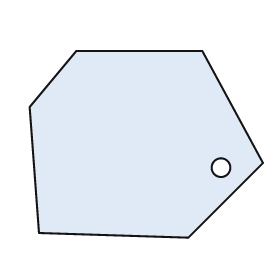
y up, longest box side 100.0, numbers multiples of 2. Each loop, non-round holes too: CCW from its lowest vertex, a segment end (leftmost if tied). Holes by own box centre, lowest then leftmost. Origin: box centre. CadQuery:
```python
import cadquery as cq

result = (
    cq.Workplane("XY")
    .moveTo(18.0, -40.0)
    .lineTo(50.0, -8.0)
    .lineTo(24.0, 40.0)
    .lineTo(-30.0, 40.0)
    .lineTo(-50.0, 16.0)
    .lineTo(-46.0, -38.0)
    .close()
    .moveTo(32.0, -10.0)
    .circle(4.0)
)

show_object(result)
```